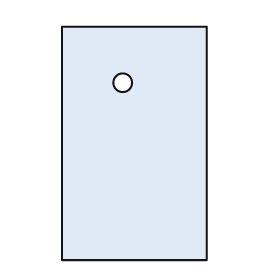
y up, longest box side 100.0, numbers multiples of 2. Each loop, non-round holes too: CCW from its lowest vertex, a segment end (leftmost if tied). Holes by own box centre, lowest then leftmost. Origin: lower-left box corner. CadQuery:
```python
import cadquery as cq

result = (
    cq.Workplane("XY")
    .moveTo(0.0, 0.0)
    .lineTo(62.0, 0.0)
    .lineTo(62.0, 100.0)
    .lineTo(0.0, 100.0)
    .close()
    .moveTo(26.0, 76.0)
    .circle(4.0)
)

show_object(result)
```